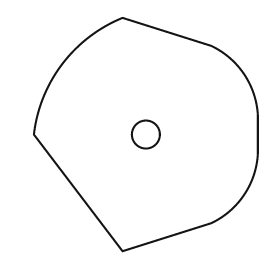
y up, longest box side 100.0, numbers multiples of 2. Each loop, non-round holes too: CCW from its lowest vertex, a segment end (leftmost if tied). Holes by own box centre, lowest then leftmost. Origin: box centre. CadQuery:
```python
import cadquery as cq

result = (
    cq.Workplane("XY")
    .moveTo(-10.0, -50.0)
    .lineTo(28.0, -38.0)
    .threePointArc((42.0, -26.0), (48.0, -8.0))
    .lineTo(48.0, 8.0)
    .threePointArc((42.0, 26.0), (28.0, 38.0))
    .lineTo(-10.0, 50.0)
    .threePointArc((-36.0, 30.0), (-48.0, 0.0))
    .close()
    .moveTo(0.0, 0.0)
    .circle(6.0)
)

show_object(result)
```